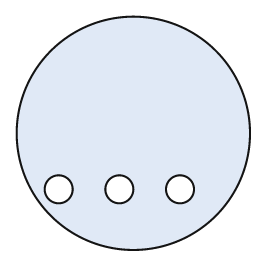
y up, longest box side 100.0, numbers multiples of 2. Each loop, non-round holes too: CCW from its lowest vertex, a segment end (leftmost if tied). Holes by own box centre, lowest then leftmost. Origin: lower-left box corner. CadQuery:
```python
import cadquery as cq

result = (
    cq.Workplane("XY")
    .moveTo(50.0, 50.0)
    .circle(50.0)
    .moveTo(18.0, 26.0)
    .circle(6.0)
    .moveTo(44.0, 26.0)
    .circle(6.0)
    .moveTo(70.0, 26.0)
    .circle(6.0)
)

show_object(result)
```